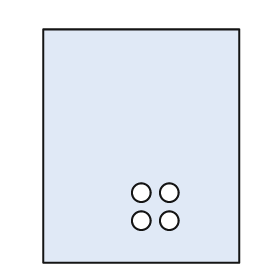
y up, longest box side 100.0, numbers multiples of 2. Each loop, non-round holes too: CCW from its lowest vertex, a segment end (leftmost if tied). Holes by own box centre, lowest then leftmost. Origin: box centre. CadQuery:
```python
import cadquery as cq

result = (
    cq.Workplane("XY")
    .moveTo(-42.0, -50.0)
    .lineTo(42.0, -50.0)
    .lineTo(42.0, 50.0)
    .lineTo(-42.0, 50.0)
    .close()
    .moveTo(0.0, -32.0)
    .circle(4.0)
    .moveTo(12.0, -32.0)
    .circle(4.0)
    .moveTo(0.0, -20.0)
    .circle(4.0)
    .moveTo(12.0, -20.0)
    .circle(4.0)
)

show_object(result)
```